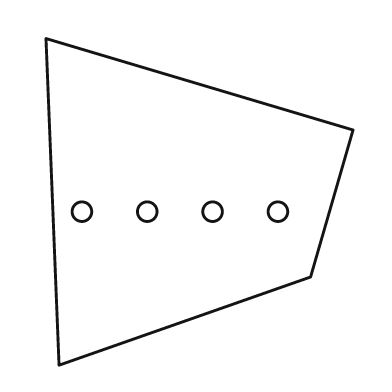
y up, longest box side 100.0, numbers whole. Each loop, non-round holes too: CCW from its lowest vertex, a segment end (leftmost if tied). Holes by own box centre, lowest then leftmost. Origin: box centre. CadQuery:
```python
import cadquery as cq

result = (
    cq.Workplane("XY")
    .moveTo(-43.0, -50.0)
    .lineTo(34.0, -23.0)
    .lineTo(47.0, 22.0)
    .lineTo(-47.0, 50.0)
    .close()
    .moveTo(-36.0, -3.0)
    .circle(3.0)
    .moveTo(-16.0, -3.0)
    .circle(3.0)
    .moveTo(4.0, -3.0)
    .circle(3.0)
    .moveTo(24.0, -3.0)
    .circle(3.0)
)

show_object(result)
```